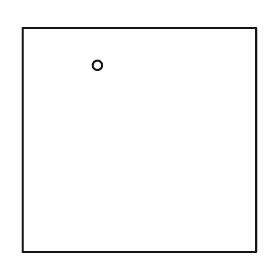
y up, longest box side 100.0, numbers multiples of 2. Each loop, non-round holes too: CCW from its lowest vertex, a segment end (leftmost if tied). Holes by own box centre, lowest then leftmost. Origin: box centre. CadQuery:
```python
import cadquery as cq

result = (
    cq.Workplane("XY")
    .moveTo(-50.0, -48.0)
    .lineTo(50.0, -48.0)
    .lineTo(50.0, 48.0)
    .lineTo(-50.0, 48.0)
    .close()
    .moveTo(-18.0, 32.0)
    .circle(2.0)
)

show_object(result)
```